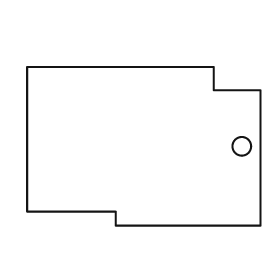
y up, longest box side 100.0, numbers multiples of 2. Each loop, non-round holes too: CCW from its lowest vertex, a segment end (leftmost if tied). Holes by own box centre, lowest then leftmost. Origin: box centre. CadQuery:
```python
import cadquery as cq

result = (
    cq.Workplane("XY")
    .moveTo(-12.0, -34.0)
    .lineTo(50.0, -34.0)
    .lineTo(50.0, 24.0)
    .lineTo(30.0, 24.0)
    .lineTo(30.0, 34.0)
    .lineTo(-50.0, 34.0)
    .lineTo(-50.0, -28.0)
    .lineTo(-12.0, -28.0)
    .close()
    .moveTo(42.0, 0.0)
    .circle(4.0)
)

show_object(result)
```